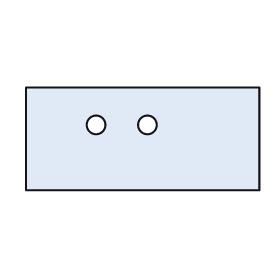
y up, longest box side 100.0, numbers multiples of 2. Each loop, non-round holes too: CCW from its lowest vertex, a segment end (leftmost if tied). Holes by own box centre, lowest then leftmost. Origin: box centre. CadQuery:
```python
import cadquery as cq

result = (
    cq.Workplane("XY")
    .moveTo(-50.0, -22.0)
    .lineTo(50.0, -22.0)
    .lineTo(50.0, 22.0)
    .lineTo(-50.0, 22.0)
    .close()
    .moveTo(-20.0, 6.0)
    .circle(4.0)
    .moveTo(2.0, 6.0)
    .circle(4.0)
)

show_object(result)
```